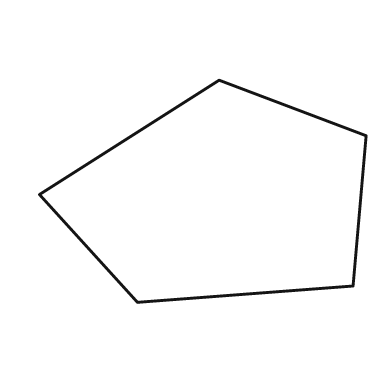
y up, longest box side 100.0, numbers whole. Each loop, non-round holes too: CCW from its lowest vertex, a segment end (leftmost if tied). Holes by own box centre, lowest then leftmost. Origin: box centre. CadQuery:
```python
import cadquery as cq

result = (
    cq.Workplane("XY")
    .moveTo(-20.0, -34.0)
    .lineTo(46.0, -29.0)
    .lineTo(50.0, 17.0)
    .lineTo(5.0, 34.0)
    .lineTo(-50.0, -1.0)
    .close()
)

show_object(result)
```